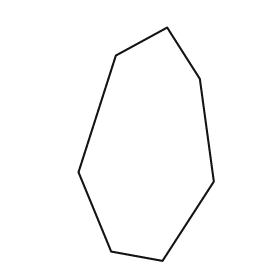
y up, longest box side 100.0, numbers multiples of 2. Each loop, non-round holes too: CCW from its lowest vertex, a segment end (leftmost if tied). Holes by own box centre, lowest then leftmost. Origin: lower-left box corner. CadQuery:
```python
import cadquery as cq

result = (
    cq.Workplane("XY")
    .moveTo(36.0, 0.0)
    .lineTo(58.0, 34.0)
    .lineTo(52.0, 78.0)
    .lineTo(38.0, 100.0)
    .lineTo(16.0, 88.0)
    .lineTo(0.0, 38.0)
    .lineTo(14.0, 4.0)
    .close()
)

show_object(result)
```